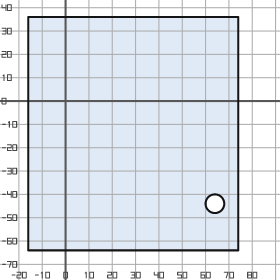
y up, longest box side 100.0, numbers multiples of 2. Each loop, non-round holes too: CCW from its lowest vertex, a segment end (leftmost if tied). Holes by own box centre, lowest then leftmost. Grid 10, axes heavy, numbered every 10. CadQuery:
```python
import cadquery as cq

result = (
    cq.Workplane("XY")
    .moveTo(-16.0, -64.0)
    .lineTo(74.0, -64.0)
    .lineTo(74.0, 36.0)
    .lineTo(-16.0, 36.0)
    .close()
    .moveTo(64.0, -44.0)
    .circle(4.0)
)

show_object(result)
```